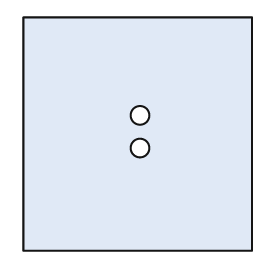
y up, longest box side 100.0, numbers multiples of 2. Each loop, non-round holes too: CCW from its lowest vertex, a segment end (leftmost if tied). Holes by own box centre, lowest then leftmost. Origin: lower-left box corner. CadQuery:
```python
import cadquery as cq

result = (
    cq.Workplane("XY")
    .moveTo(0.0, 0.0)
    .lineTo(98.0, 0.0)
    .lineTo(98.0, 100.0)
    .lineTo(0.0, 100.0)
    .close()
    .moveTo(50.0, 44.0)
    .circle(4.0)
    .moveTo(50.0, 58.0)
    .circle(4.0)
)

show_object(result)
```